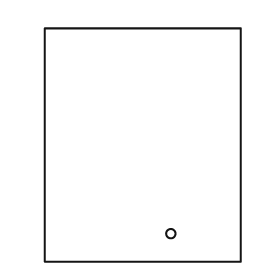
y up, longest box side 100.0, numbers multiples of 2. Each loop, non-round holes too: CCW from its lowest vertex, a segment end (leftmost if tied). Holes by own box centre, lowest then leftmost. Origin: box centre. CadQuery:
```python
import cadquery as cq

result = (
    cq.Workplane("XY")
    .moveTo(-42.0, -50.0)
    .lineTo(42.0, -50.0)
    .lineTo(42.0, 50.0)
    .lineTo(-42.0, 50.0)
    .close()
    .moveTo(12.0, -38.0)
    .circle(2.0)
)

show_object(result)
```